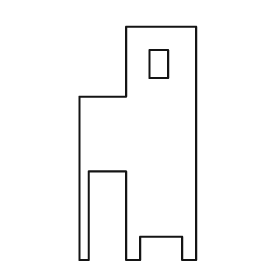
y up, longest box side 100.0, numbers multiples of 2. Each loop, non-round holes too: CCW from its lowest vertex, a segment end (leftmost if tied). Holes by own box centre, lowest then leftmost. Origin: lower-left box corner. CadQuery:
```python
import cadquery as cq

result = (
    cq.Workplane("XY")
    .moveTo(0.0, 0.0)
    .lineTo(4.0, 0.0)
    .lineTo(4.0, 38.0)
    .lineTo(20.0, 38.0)
    .lineTo(20.0, 0.0)
    .lineTo(26.0, 0.0)
    .lineTo(26.0, 10.0)
    .lineTo(44.0, 10.0)
    .lineTo(44.0, 0.0)
    .lineTo(50.0, 0.0)
    .lineTo(50.0, 100.0)
    .lineTo(20.0, 100.0)
    .lineTo(20.0, 70.0)
    .lineTo(0.0, 70.0)
    .close()
    .moveTo(30.0, 78.0)
    .lineTo(38.0, 78.0)
    .lineTo(38.0, 90.0)
    .lineTo(30.0, 90.0)
    .close()
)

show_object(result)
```